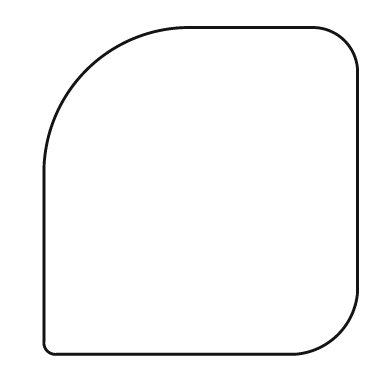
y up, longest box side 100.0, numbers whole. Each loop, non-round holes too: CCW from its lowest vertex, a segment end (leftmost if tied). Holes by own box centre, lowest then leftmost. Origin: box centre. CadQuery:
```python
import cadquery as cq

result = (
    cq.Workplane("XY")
    .moveTo(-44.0, -50.0)
    .lineTo(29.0, -50.0)
    .threePointArc((42.0, -44.0), (48.0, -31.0))
    .lineTo(48.0, 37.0)
    .threePointArc((44.0, 46.0), (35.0, 50.0))
    .lineTo(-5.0, 50.0)
    .threePointArc((-35.0, 37.0), (-48.0, 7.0))
    .lineTo(-48.0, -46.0)
    .threePointArc((-47.0, -49.0), (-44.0, -50.0))
    .close()
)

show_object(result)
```